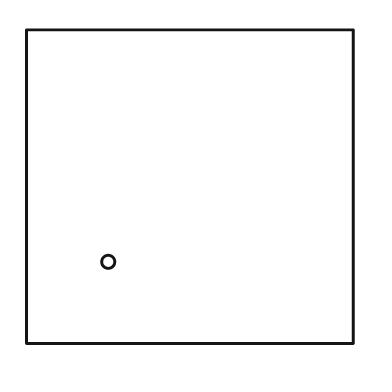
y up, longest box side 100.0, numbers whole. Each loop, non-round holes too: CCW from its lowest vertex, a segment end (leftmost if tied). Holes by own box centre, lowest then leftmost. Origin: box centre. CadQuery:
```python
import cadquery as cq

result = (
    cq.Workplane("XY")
    .moveTo(-50.0, -48.0)
    .lineTo(50.0, -48.0)
    .lineTo(50.0, 48.0)
    .lineTo(-50.0, 48.0)
    .close()
    .moveTo(-25.0, -23.0)
    .circle(2.0)
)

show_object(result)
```